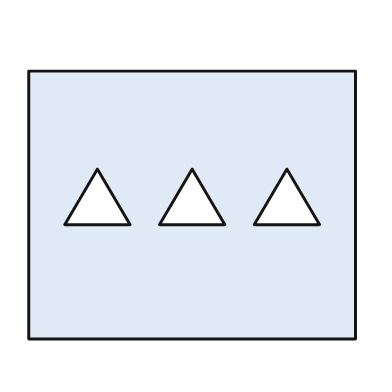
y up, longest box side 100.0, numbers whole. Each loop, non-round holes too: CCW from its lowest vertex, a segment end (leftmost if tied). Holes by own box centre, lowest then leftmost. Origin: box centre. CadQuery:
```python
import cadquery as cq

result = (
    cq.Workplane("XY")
    .moveTo(-50.0, -41.0)
    .lineTo(50.0, -41.0)
    .lineTo(50.0, 41.0)
    .lineTo(-50.0, 41.0)
    .close()
    .moveTo(-39.0, -6.0)
    .lineTo(-19.0, -6.0)
    .lineTo(-29.0, 11.0)
    .close()
    .moveTo(-10.0, -6.0)
    .lineTo(10.0, -6.0)
    .lineTo(0.0, 11.0)
    .close()
    .moveTo(19.0, -6.0)
    .lineTo(39.0, -6.0)
    .lineTo(29.0, 11.0)
    .close()
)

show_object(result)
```